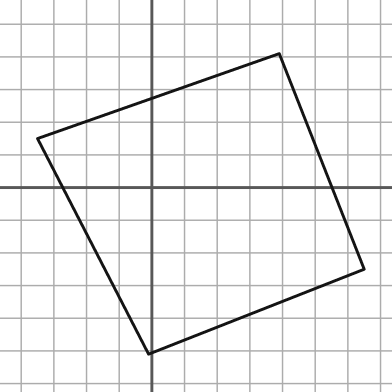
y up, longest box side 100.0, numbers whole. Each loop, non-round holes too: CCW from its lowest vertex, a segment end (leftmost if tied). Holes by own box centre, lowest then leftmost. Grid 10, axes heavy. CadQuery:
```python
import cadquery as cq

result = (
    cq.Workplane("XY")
    .moveTo(-1.0, -51.0)
    .lineTo(65.0, -25.0)
    .lineTo(39.0, 41.0)
    .lineTo(-35.0, 15.0)
    .close()
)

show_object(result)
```